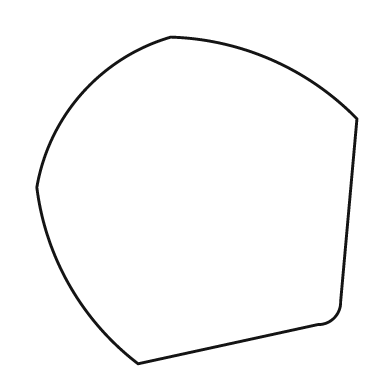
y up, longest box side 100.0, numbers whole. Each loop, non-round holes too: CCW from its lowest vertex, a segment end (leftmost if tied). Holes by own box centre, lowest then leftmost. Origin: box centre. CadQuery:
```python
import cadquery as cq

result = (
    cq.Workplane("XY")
    .moveTo(-18.0, -50.0)
    .lineTo(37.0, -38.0)
    .threePointArc((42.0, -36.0), (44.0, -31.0))
    .lineTo(49.0, 25.0)
    .threePointArc((23.0, 43.0), (-8.0, 50.0))
    .threePointArc((-35.0, 33.0), (-49.0, 4.0))
    .threePointArc((-39.0, -26.0), (-18.0, -50.0))
    .close()
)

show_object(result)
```